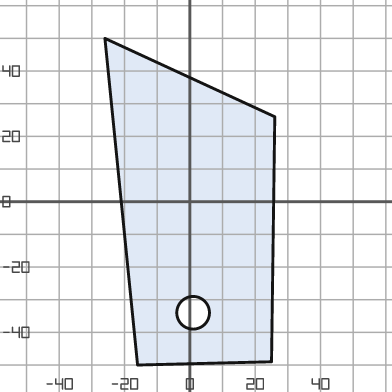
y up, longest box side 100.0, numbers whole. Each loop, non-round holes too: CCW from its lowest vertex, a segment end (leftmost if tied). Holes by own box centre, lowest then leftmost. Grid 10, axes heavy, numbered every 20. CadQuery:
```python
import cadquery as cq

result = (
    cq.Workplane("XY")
    .moveTo(-16.0, -50.0)
    .lineTo(25.0, -49.0)
    .lineTo(26.0, 26.0)
    .lineTo(-26.0, 50.0)
    .close()
    .moveTo(1.0, -34.0)
    .circle(5.0)
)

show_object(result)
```